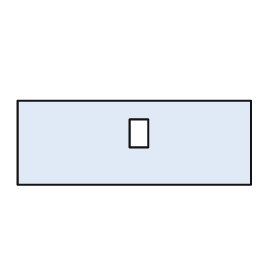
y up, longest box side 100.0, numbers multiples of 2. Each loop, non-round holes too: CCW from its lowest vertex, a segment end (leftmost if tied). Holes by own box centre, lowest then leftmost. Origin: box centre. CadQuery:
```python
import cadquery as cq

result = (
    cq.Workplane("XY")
    .moveTo(-50.0, -18.0)
    .lineTo(50.0, -18.0)
    .lineTo(50.0, 18.0)
    .lineTo(-50.0, 18.0)
    .close()
    .moveTo(-2.0, -2.0)
    .lineTo(6.0, -2.0)
    .lineTo(6.0, 10.0)
    .lineTo(-2.0, 10.0)
    .close()
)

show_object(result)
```